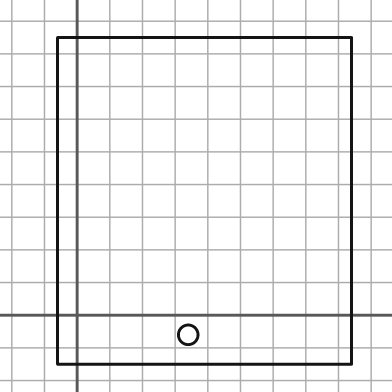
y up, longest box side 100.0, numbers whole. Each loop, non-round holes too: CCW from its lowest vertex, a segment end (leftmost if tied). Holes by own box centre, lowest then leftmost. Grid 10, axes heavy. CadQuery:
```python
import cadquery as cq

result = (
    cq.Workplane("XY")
    .moveTo(-6.0, -15.0)
    .lineTo(84.0, -15.0)
    .lineTo(84.0, 85.0)
    .lineTo(-6.0, 85.0)
    .close()
    .moveTo(34.0, -6.0)
    .circle(3.0)
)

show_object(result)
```